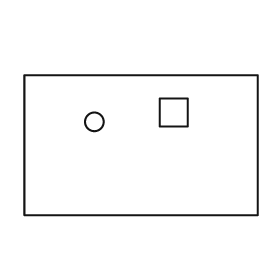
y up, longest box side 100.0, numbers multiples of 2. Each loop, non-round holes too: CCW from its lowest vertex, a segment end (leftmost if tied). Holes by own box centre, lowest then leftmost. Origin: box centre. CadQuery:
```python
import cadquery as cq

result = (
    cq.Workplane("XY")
    .moveTo(-50.0, -30.0)
    .lineTo(50.0, -30.0)
    .lineTo(50.0, 30.0)
    .lineTo(-50.0, 30.0)
    .close()
    .moveTo(-20.0, 10.0)
    .circle(4.0)
    .moveTo(8.0, 8.0)
    .lineTo(20.0, 8.0)
    .lineTo(20.0, 20.0)
    .lineTo(8.0, 20.0)
    .close()
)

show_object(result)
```